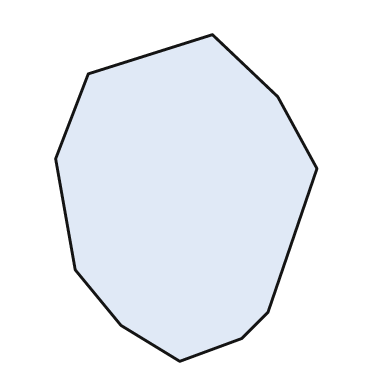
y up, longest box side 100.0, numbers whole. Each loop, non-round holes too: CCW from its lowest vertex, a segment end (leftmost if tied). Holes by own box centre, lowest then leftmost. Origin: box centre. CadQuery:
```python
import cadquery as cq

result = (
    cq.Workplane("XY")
    .moveTo(-2.0, -50.0)
    .lineTo(17.0, -43.0)
    .lineTo(25.0, -35.0)
    .lineTo(40.0, 9.0)
    .lineTo(28.0, 31.0)
    .lineTo(8.0, 50.0)
    .lineTo(-30.0, 38.0)
    .lineTo(-40.0, 12.0)
    .lineTo(-34.0, -22.0)
    .lineTo(-20.0, -39.0)
    .close()
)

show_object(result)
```